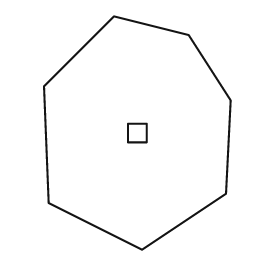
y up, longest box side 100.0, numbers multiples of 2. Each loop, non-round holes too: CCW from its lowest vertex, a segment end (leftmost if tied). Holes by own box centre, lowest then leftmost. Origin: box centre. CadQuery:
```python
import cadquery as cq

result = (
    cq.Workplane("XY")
    .moveTo(2.0, -50.0)
    .lineTo(38.0, -26.0)
    .lineTo(40.0, 14.0)
    .lineTo(22.0, 42.0)
    .lineTo(-10.0, 50.0)
    .lineTo(-40.0, 20.0)
    .lineTo(-38.0, -30.0)
    .close()
    .moveTo(-4.0, -4.0)
    .lineTo(4.0, -4.0)
    .lineTo(4.0, 4.0)
    .lineTo(-4.0, 4.0)
    .close()
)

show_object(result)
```